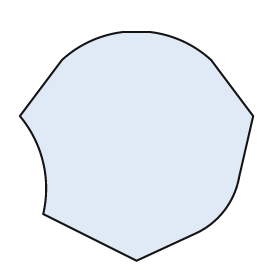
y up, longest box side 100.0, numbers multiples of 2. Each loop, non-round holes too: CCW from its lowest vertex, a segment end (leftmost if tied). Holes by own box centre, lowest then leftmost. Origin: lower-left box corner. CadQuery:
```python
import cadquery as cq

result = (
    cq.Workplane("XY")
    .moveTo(50.0, 0.0)
    .lineTo(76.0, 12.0)
    .threePointArc((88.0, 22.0), (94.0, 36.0))
    .lineTo(100.0, 62.0)
    .lineTo(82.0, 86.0)
    .threePointArc((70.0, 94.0), (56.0, 98.0))
    .lineTo(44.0, 98.0)
    .threePointArc((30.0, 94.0), (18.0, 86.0))
    .lineTo(0.0, 62.0)
    .threePointArc((10.0, 42.0), (10.0, 20.0))
    .close()
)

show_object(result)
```